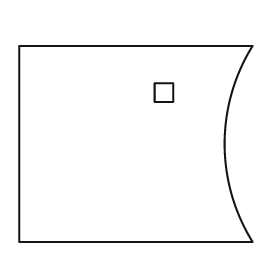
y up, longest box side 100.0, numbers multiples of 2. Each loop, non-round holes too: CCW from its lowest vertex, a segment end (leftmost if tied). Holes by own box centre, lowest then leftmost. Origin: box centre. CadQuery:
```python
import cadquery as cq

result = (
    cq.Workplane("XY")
    .moveTo(-50.0, -42.0)
    .lineTo(50.0, -42.0)
    .threePointArc((38.0, 0.0), (50.0, 42.0))
    .lineTo(-50.0, 42.0)
    .close()
    .moveTo(8.0, 18.0)
    .lineTo(16.0, 18.0)
    .lineTo(16.0, 26.0)
    .lineTo(8.0, 26.0)
    .close()
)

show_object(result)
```